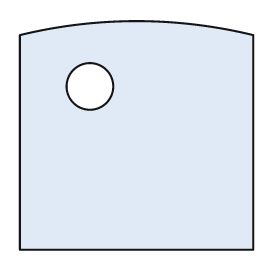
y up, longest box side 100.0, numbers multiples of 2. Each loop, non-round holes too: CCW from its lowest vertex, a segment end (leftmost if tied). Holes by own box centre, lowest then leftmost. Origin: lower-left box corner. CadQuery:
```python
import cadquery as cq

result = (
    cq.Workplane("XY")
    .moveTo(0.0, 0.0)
    .lineTo(100.0, 0.0)
    .lineTo(100.0, 92.0)
    .threePointArc((50.0, 98.0), (0.0, 92.0))
    .close()
    .moveTo(30.0, 70.0)
    .circle(10.0)
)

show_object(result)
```